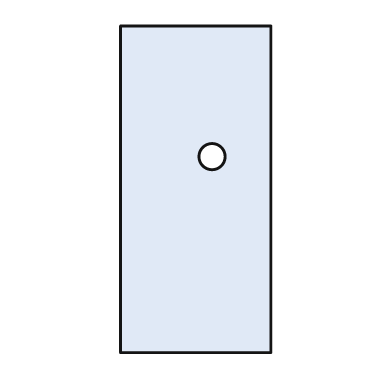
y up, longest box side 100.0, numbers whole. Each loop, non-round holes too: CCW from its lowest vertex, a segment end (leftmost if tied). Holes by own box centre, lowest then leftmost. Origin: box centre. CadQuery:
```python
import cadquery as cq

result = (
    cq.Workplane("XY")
    .moveTo(-23.0, -50.0)
    .lineTo(23.0, -50.0)
    .lineTo(23.0, 50.0)
    .lineTo(-23.0, 50.0)
    .close()
    .moveTo(5.0, 10.0)
    .circle(4.0)
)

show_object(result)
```